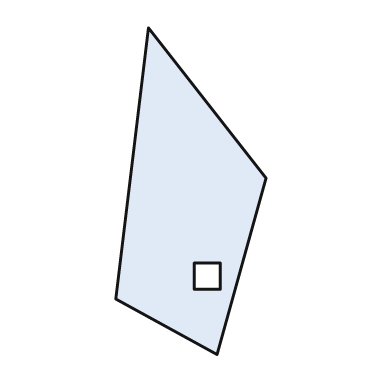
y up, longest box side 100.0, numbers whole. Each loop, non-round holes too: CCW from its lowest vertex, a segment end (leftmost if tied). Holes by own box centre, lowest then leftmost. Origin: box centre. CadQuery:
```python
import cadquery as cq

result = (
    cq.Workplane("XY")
    .moveTo(8.0, -50.0)
    .lineTo(23.0, 4.0)
    .lineTo(-13.0, 50.0)
    .lineTo(-23.0, -33.0)
    .close()
    .moveTo(1.0, -30.0)
    .lineTo(9.0, -30.0)
    .lineTo(9.0, -22.0)
    .lineTo(1.0, -22.0)
    .close()
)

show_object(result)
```